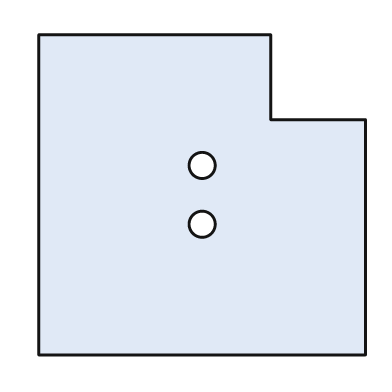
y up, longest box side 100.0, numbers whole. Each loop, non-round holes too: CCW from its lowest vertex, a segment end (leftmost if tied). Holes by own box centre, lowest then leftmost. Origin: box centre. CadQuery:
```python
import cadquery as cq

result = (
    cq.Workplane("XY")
    .moveTo(-50.0, -49.0)
    .lineTo(50.0, -49.0)
    .lineTo(50.0, 23.0)
    .lineTo(21.0, 23.0)
    .lineTo(21.0, 49.0)
    .lineTo(-50.0, 49.0)
    .close()
    .moveTo(0.0, -9.0)
    .circle(4.0)
    .moveTo(0.0, 9.0)
    .circle(4.0)
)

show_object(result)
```